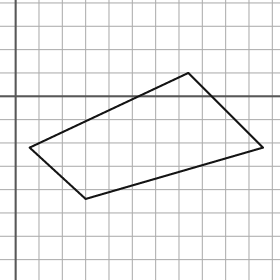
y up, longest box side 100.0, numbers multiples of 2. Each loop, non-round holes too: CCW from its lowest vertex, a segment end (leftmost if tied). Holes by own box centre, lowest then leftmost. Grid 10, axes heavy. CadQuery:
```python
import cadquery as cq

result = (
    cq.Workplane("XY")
    .moveTo(30.0, -44.0)
    .lineTo(106.0, -22.0)
    .lineTo(74.0, 10.0)
    .lineTo(6.0, -22.0)
    .close()
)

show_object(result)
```